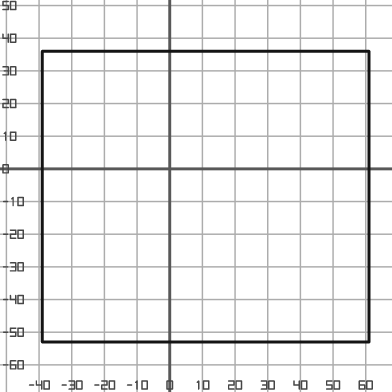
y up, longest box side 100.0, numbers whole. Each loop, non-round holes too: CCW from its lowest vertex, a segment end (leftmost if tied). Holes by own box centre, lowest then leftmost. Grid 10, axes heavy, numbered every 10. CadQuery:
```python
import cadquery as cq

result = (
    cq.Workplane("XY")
    .moveTo(-39.0, -53.0)
    .lineTo(61.0, -53.0)
    .lineTo(61.0, 36.0)
    .lineTo(-39.0, 36.0)
    .close()
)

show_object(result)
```